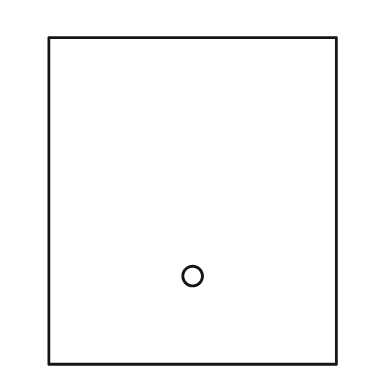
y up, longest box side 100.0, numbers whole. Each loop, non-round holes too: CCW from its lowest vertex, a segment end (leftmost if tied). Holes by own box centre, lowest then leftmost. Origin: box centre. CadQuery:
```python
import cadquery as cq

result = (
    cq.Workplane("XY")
    .moveTo(-44.0, -50.0)
    .lineTo(44.0, -50.0)
    .lineTo(44.0, 50.0)
    .lineTo(-44.0, 50.0)
    .close()
    .moveTo(0.0, -23.0)
    .circle(3.0)
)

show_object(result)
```